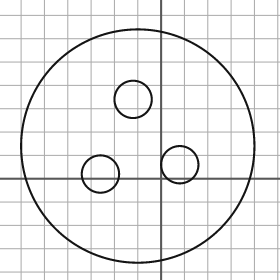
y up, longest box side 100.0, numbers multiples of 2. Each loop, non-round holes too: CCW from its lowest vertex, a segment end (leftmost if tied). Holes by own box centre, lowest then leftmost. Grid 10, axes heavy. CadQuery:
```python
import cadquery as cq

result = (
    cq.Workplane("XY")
    .moveTo(-10.0, 14.0)
    .circle(50.0)
    .moveTo(-26.0, 2.0)
    .circle(8.0)
    .moveTo(8.0, 6.0)
    .circle(8.0)
    .moveTo(-12.0, 34.0)
    .circle(8.0)
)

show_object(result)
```